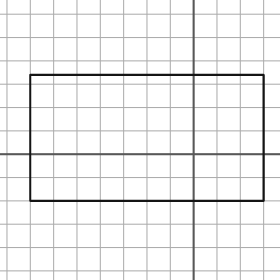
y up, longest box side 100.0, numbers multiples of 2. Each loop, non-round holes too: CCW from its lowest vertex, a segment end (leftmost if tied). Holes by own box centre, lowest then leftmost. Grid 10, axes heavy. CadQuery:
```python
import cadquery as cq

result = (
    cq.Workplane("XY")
    .moveTo(-70.0, -20.0)
    .lineTo(30.0, -20.0)
    .lineTo(30.0, 34.0)
    .lineTo(-70.0, 34.0)
    .close()
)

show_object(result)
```